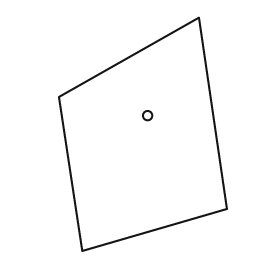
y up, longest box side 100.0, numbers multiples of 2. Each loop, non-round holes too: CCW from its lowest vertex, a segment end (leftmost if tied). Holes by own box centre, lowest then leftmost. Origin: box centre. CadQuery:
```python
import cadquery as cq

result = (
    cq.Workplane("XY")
    .moveTo(-26.0, -50.0)
    .lineTo(36.0, -32.0)
    .lineTo(24.0, 50.0)
    .lineTo(-36.0, 16.0)
    .close()
    .moveTo(2.0, 8.0)
    .circle(2.0)
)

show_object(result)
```